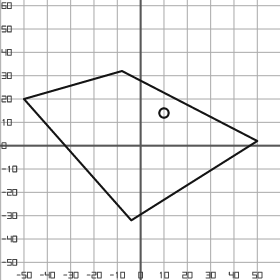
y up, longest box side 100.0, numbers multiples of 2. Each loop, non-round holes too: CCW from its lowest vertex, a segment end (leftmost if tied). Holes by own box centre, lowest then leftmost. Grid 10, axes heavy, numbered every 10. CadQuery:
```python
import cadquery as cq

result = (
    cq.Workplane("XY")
    .moveTo(-4.0, -32.0)
    .lineTo(50.0, 2.0)
    .lineTo(-8.0, 32.0)
    .lineTo(-50.0, 20.0)
    .close()
    .moveTo(10.0, 14.0)
    .circle(2.0)
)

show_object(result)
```